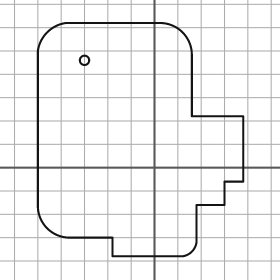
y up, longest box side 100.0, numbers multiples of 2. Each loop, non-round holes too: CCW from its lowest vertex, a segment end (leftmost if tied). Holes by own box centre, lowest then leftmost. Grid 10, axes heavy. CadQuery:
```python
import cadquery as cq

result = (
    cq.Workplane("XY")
    .moveTo(-18.0, -38.0)
    .lineTo(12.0, -38.0)
    .threePointArc((16.0, -36.0), (18.0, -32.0))
    .lineTo(18.0, -16.0)
    .lineTo(30.0, -16.0)
    .lineTo(30.0, -6.0)
    .lineTo(38.0, -6.0)
    .lineTo(38.0, 22.0)
    .lineTo(16.0, 22.0)
    .lineTo(16.0, 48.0)
    .threePointArc((12.0, 58.0), (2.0, 62.0))
    .lineTo(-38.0, 62.0)
    .threePointArc((-46.0, 58.0), (-50.0, 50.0))
    .lineTo(-50.0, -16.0)
    .threePointArc((-46.0, -26.0), (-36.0, -30.0))
    .lineTo(-18.0, -30.0)
    .close()
    .moveTo(-30.0, 46.0)
    .circle(2.0)
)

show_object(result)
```